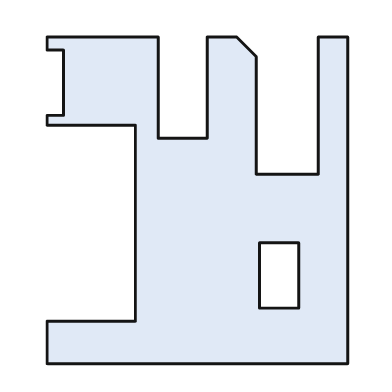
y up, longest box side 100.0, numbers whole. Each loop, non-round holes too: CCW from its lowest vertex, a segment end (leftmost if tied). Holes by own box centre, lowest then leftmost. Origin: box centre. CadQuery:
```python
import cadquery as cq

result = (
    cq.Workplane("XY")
    .moveTo(-46.0, -50.0)
    .lineTo(46.0, -50.0)
    .lineTo(46.0, 50.0)
    .lineTo(37.0, 50.0)
    .lineTo(37.0, 8.0)
    .lineTo(18.0, 8.0)
    .lineTo(18.0, 44.0)
    .lineTo(12.0, 50.0)
    .lineTo(3.0, 50.0)
    .lineTo(3.0, 19.0)
    .lineTo(-12.0, 19.0)
    .lineTo(-12.0, 50.0)
    .lineTo(-46.0, 50.0)
    .lineTo(-46.0, 46.0)
    .lineTo(-41.0, 46.0)
    .lineTo(-41.0, 26.0)
    .lineTo(-46.0, 26.0)
    .lineTo(-46.0, 23.0)
    .lineTo(-19.0, 23.0)
    .lineTo(-19.0, -37.0)
    .lineTo(-46.0, -37.0)
    .close()
    .moveTo(19.0, -33.0)
    .lineTo(31.0, -33.0)
    .lineTo(31.0, -13.0)
    .lineTo(19.0, -13.0)
    .close()
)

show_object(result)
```